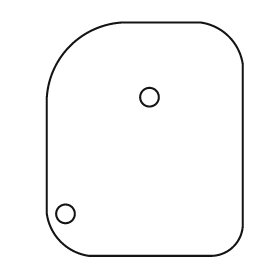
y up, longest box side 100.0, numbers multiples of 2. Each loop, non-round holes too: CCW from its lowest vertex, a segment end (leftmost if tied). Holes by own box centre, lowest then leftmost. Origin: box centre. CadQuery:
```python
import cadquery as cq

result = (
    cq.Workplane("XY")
    .moveTo(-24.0, -50.0)
    .lineTo(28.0, -50.0)
    .threePointArc((38.0, -46.0), (42.0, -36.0))
    .lineTo(42.0, 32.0)
    .threePointArc((36.0, 44.0), (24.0, 50.0))
    .lineTo(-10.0, 50.0)
    .threePointArc((-32.0, 40.0), (-42.0, 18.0))
    .lineTo(-42.0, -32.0)
    .threePointArc((-36.0, -44.0), (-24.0, -50.0))
    .close()
    .moveTo(-34.0, -32.0)
    .circle(4.0)
    .moveTo(2.0, 18.0)
    .circle(4.0)
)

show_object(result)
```